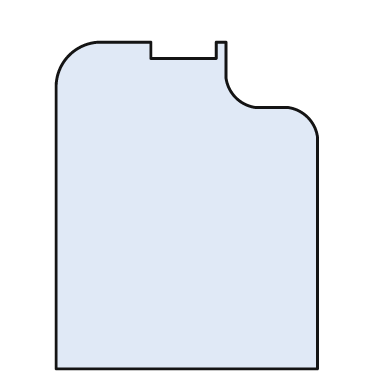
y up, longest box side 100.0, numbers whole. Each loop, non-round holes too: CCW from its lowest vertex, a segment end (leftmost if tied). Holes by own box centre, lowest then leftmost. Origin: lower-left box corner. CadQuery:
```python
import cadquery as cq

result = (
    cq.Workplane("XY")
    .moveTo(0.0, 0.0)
    .lineTo(80.0, 0.0)
    .lineTo(80.0, 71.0)
    .threePointArc((77.0, 77.0), (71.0, 80.0))
    .lineTo(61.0, 80.0)
    .threePointArc((55.0, 83.0), (52.0, 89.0))
    .lineTo(52.0, 100.0)
    .lineTo(49.0, 100.0)
    .lineTo(49.0, 95.0)
    .lineTo(29.0, 95.0)
    .lineTo(29.0, 100.0)
    .lineTo(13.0, 100.0)
    .threePointArc((4.0, 96.0), (0.0, 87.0))
    .close()
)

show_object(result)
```